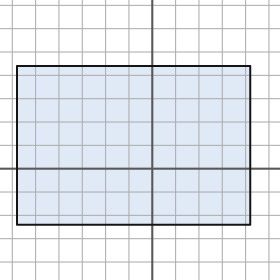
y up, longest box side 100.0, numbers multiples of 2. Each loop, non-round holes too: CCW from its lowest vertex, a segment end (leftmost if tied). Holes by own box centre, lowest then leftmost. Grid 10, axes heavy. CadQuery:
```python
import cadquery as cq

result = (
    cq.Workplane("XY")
    .moveTo(-58.0, -24.0)
    .lineTo(42.0, -24.0)
    .lineTo(42.0, 44.0)
    .lineTo(-58.0, 44.0)
    .close()
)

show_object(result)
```